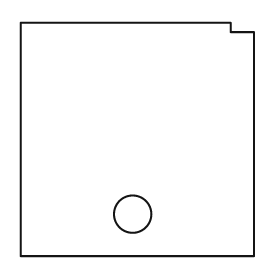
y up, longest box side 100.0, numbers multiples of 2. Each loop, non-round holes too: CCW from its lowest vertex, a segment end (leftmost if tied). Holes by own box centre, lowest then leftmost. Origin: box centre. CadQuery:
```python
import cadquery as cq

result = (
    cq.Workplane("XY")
    .moveTo(-50.0, -50.0)
    .lineTo(50.0, -50.0)
    .lineTo(50.0, 46.0)
    .lineTo(40.0, 46.0)
    .lineTo(40.0, 50.0)
    .lineTo(-50.0, 50.0)
    .close()
    .moveTo(-2.0, -32.0)
    .circle(8.0)
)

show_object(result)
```